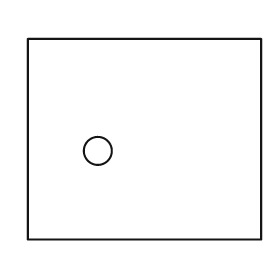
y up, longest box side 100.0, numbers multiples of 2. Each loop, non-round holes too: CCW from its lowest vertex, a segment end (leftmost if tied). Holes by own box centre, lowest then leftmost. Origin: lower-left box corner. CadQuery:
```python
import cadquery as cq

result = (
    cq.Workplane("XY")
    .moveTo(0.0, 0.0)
    .lineTo(100.0, 0.0)
    .lineTo(100.0, 86.0)
    .lineTo(0.0, 86.0)
    .close()
    .moveTo(30.0, 38.0)
    .circle(6.0)
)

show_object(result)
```